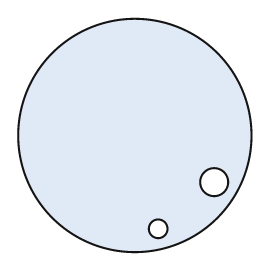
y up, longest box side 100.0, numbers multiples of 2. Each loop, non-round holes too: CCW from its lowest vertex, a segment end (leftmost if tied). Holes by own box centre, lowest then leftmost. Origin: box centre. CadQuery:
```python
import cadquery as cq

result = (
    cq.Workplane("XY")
    .moveTo(0.0, 0.0)
    .circle(50.0)
    .moveTo(10.0, -40.0)
    .circle(4.0)
    .moveTo(34.0, -20.0)
    .circle(6.0)
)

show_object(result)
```